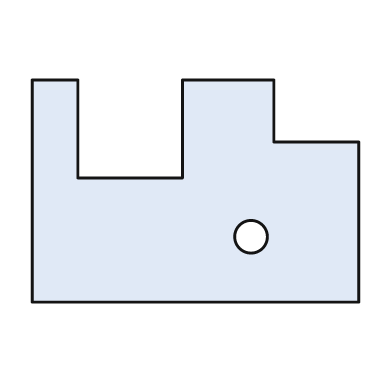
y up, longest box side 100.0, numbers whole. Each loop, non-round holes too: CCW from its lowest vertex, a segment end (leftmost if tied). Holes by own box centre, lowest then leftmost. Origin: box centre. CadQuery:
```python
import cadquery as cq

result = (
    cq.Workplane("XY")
    .moveTo(-50.0, -34.0)
    .lineTo(50.0, -34.0)
    .lineTo(50.0, 15.0)
    .lineTo(24.0, 15.0)
    .lineTo(24.0, 34.0)
    .lineTo(-4.0, 34.0)
    .lineTo(-4.0, 4.0)
    .lineTo(-36.0, 4.0)
    .lineTo(-36.0, 34.0)
    .lineTo(-50.0, 34.0)
    .close()
    .moveTo(17.0, -14.0)
    .circle(5.0)
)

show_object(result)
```